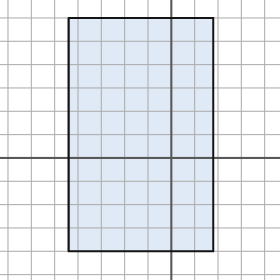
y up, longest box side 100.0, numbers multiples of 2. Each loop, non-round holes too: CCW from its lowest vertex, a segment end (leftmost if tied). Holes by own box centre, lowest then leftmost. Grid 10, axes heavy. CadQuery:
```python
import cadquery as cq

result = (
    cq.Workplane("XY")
    .moveTo(-44.0, -40.0)
    .lineTo(18.0, -40.0)
    .lineTo(18.0, 60.0)
    .lineTo(-44.0, 60.0)
    .close()
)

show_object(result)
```